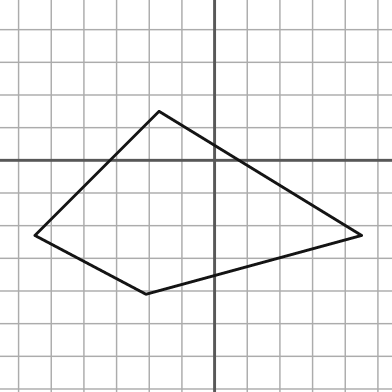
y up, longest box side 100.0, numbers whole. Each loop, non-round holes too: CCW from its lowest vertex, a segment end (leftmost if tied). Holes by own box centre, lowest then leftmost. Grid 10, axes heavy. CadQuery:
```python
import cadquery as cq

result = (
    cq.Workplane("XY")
    .moveTo(-21.0, -41.0)
    .lineTo(45.0, -23.0)
    .lineTo(-17.0, 15.0)
    .lineTo(-55.0, -23.0)
    .close()
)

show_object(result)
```